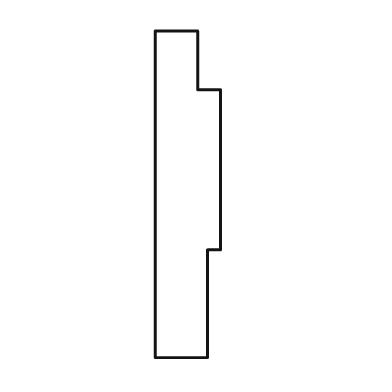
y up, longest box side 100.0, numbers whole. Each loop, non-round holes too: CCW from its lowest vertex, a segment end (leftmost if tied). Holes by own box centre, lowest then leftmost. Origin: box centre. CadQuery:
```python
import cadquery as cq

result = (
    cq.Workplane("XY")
    .moveTo(-10.0, -50.0)
    .lineTo(6.0, -50.0)
    .lineTo(6.0, -17.0)
    .lineTo(10.0, -17.0)
    .lineTo(10.0, 32.0)
    .lineTo(3.0, 32.0)
    .lineTo(3.0, 50.0)
    .lineTo(-10.0, 50.0)
    .close()
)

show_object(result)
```